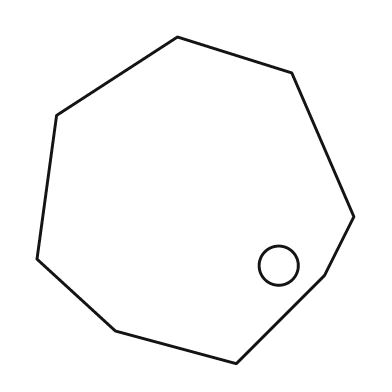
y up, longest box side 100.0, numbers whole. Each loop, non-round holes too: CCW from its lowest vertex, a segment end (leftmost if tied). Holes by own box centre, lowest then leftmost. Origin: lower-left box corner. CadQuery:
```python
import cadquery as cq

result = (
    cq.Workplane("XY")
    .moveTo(61.0, 0.0)
    .lineTo(88.0, 27.0)
    .lineTo(97.0, 45.0)
    .lineTo(78.0, 89.0)
    .lineTo(43.0, 100.0)
    .lineTo(6.0, 76.0)
    .lineTo(0.0, 32.0)
    .lineTo(24.0, 10.0)
    .close()
    .moveTo(74.0, 30.0)
    .circle(6.0)
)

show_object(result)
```